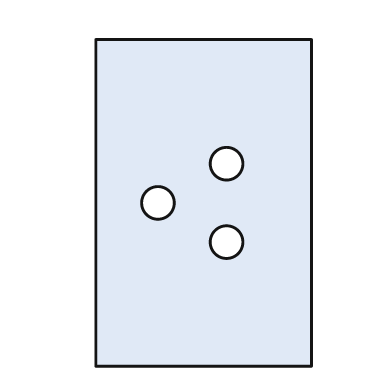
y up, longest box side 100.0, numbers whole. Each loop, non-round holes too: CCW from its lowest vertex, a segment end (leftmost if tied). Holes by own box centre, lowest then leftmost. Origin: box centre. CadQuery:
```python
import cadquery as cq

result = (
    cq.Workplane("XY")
    .moveTo(-33.0, -50.0)
    .lineTo(33.0, -50.0)
    .lineTo(33.0, 50.0)
    .lineTo(-33.0, 50.0)
    .close()
    .moveTo(7.0, -12.0)
    .circle(5.0)
    .moveTo(-14.0, 0.0)
    .circle(5.0)
    .moveTo(7.0, 12.0)
    .circle(5.0)
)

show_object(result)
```